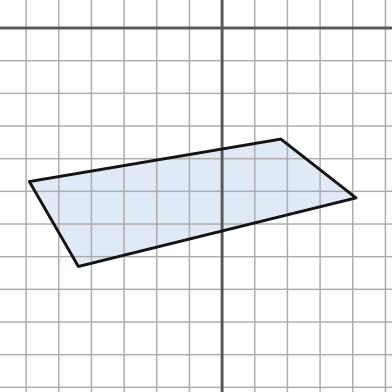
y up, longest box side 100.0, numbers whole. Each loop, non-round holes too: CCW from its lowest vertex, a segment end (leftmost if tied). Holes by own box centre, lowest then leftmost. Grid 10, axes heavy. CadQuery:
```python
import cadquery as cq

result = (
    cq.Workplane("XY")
    .moveTo(-44.0, -73.0)
    .lineTo(41.0, -52.0)
    .lineTo(18.0, -34.0)
    .lineTo(-59.0, -47.0)
    .close()
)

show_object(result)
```